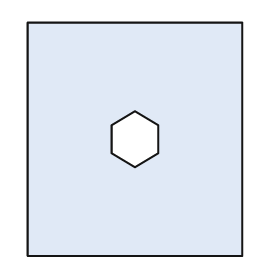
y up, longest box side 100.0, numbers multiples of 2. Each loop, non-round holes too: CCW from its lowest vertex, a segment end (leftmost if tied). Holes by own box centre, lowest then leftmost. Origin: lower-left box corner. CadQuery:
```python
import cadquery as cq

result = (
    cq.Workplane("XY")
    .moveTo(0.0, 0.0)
    .lineTo(92.0, 0.0)
    .lineTo(92.0, 100.0)
    .lineTo(0.0, 100.0)
    .close()
    .moveTo(46.0, 38.0)
    .lineTo(56.0, 44.0)
    .lineTo(56.0, 56.0)
    .lineTo(46.0, 62.0)
    .lineTo(36.0, 56.0)
    .lineTo(36.0, 44.0)
    .close()
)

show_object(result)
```